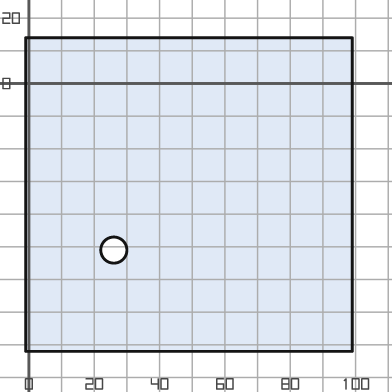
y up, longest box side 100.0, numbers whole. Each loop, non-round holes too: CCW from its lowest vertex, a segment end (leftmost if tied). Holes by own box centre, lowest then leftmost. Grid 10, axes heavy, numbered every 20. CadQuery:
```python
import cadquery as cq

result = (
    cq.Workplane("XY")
    .moveTo(-1.0, -82.0)
    .lineTo(99.0, -82.0)
    .lineTo(99.0, 14.0)
    .lineTo(-1.0, 14.0)
    .close()
    .moveTo(26.0, -51.0)
    .circle(4.0)
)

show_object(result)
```